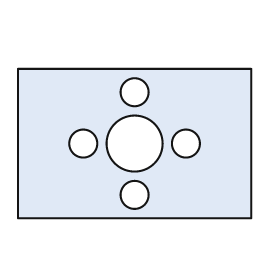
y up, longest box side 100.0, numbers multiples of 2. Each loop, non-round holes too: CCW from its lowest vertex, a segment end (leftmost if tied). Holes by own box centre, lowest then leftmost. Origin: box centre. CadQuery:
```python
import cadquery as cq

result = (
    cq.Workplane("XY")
    .moveTo(-50.0, -32.0)
    .lineTo(50.0, -32.0)
    .lineTo(50.0, 32.0)
    .lineTo(-50.0, 32.0)
    .close()
    .moveTo(0.0, -22.0)
    .circle(6.0)
    .moveTo(-22.0, 0.0)
    .circle(6.0)
    .moveTo(0.0, 0.0)
    .circle(12.0)
    .moveTo(22.0, 0.0)
    .circle(6.0)
    .moveTo(0.0, 22.0)
    .circle(6.0)
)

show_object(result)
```